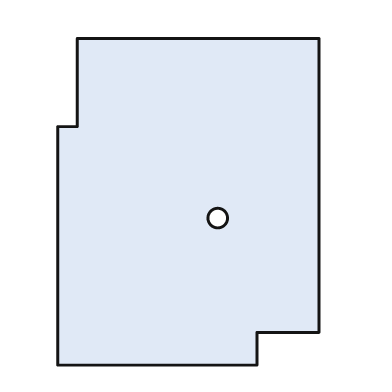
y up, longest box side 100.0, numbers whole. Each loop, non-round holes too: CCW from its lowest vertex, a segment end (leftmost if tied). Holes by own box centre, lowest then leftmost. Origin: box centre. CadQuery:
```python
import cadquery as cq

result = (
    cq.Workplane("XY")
    .moveTo(-40.0, -50.0)
    .lineTo(21.0, -50.0)
    .lineTo(21.0, -40.0)
    .lineTo(40.0, -40.0)
    .lineTo(40.0, 50.0)
    .lineTo(-34.0, 50.0)
    .lineTo(-34.0, 23.0)
    .lineTo(-40.0, 23.0)
    .close()
    .moveTo(9.0, -5.0)
    .circle(3.0)
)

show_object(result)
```